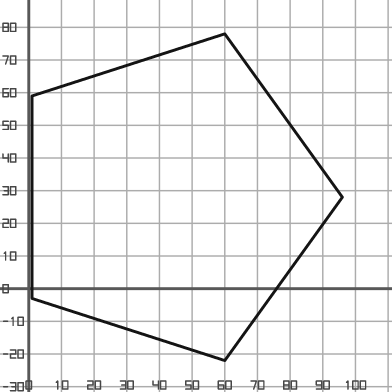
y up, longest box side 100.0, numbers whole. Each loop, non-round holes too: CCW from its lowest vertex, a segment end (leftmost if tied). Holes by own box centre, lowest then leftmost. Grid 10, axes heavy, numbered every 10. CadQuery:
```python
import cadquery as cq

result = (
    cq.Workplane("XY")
    .moveTo(60.0, -22.0)
    .lineTo(96.0, 28.0)
    .lineTo(60.0, 78.0)
    .lineTo(1.0, 59.0)
    .lineTo(1.0, -3.0)
    .close()
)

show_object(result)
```